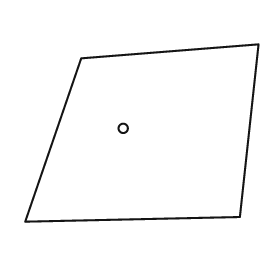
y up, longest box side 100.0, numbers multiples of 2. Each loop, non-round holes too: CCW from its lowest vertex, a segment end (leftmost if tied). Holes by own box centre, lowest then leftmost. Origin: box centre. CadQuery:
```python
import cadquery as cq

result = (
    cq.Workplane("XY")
    .moveTo(-50.0, -38.0)
    .lineTo(42.0, -36.0)
    .lineTo(50.0, 38.0)
    .lineTo(-26.0, 32.0)
    .close()
    .moveTo(-8.0, 2.0)
    .circle(2.0)
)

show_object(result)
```